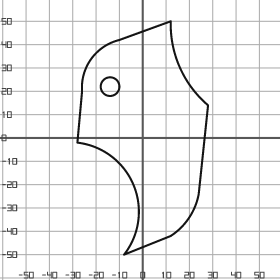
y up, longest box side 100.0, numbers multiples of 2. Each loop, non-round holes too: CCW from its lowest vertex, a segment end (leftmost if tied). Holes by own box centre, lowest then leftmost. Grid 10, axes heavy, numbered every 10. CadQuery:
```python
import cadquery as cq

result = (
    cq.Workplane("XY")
    .moveTo(-8.0, -50.0)
    .lineTo(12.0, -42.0)
    .threePointArc((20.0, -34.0), (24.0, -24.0))
    .lineTo(28.0, 14.0)
    .threePointArc((16.0, 30.0), (12.0, 50.0))
    .lineTo(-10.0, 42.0)
    .threePointArc((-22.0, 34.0), (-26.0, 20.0))
    .lineTo(-28.0, -2.0)
    .threePointArc((-4.0, -20.0), (-8.0, -50.0))
    .close()
    .moveTo(-14.0, 22.0)
    .circle(4.0)
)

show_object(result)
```